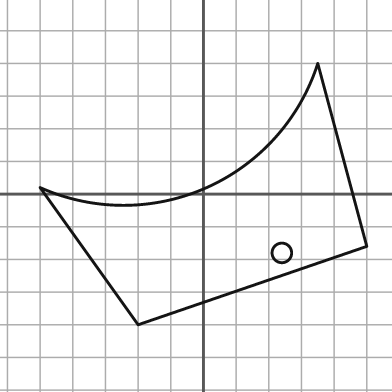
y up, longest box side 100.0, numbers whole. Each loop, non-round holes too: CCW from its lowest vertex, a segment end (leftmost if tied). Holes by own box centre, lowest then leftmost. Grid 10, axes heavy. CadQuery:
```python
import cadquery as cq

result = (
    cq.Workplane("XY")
    .moveTo(-20.0, -40.0)
    .lineTo(50.0, -16.0)
    .lineTo(35.0, 40.0)
    .threePointArc((1.0, 2.0), (-50.0, 2.0))
    .close()
    .moveTo(24.0, -18.0)
    .circle(3.0)
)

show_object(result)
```